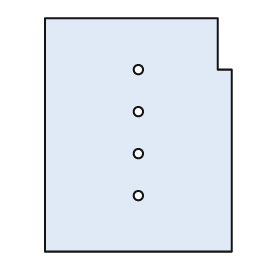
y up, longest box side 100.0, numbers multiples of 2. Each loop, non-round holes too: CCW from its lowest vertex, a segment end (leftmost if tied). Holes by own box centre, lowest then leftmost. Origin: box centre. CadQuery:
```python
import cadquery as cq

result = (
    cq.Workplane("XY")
    .moveTo(-40.0, -50.0)
    .lineTo(40.0, -50.0)
    .lineTo(40.0, 28.0)
    .lineTo(34.0, 28.0)
    .lineTo(34.0, 50.0)
    .lineTo(-40.0, 50.0)
    .close()
    .moveTo(0.0, -26.0)
    .circle(2.0)
    .moveTo(0.0, -8.0)
    .circle(2.0)
    .moveTo(0.0, 10.0)
    .circle(2.0)
    .moveTo(0.0, 28.0)
    .circle(2.0)
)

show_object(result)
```